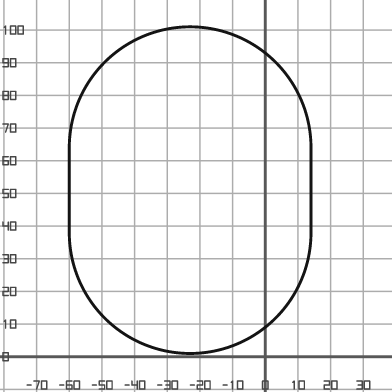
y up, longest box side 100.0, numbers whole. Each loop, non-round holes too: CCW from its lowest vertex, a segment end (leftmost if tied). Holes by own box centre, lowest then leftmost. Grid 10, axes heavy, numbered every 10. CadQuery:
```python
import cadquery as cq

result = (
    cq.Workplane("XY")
    .moveTo(-60.0, 38.0)
    .threePointArc((-23.0, 1.0), (14.0, 38.0))
    .lineTo(14.0, 64.0)
    .threePointArc((-23.0, 101.0), (-60.0, 64.0))
    .close()
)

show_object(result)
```